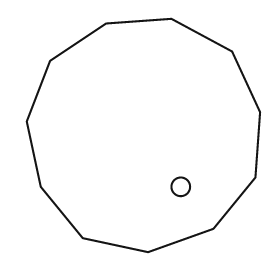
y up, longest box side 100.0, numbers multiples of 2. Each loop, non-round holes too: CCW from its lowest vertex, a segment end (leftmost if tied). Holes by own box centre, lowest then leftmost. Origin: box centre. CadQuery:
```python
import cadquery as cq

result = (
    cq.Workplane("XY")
    .moveTo(2.0, -50.0)
    .lineTo(30.0, -40.0)
    .lineTo(48.0, -18.0)
    .lineTo(50.0, 10.0)
    .lineTo(38.0, 36.0)
    .lineTo(12.0, 50.0)
    .lineTo(-16.0, 48.0)
    .lineTo(-40.0, 32.0)
    .lineTo(-50.0, 6.0)
    .lineTo(-44.0, -22.0)
    .lineTo(-26.0, -44.0)
    .close()
    .moveTo(16.0, -22.0)
    .circle(4.0)
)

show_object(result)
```